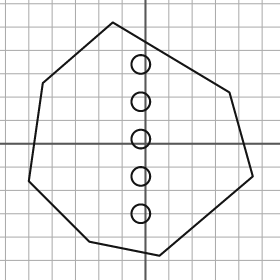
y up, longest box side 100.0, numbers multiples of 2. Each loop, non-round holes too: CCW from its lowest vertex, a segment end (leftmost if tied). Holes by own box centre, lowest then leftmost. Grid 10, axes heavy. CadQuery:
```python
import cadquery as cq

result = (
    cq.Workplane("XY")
    .moveTo(6.0, -48.0)
    .lineTo(46.0, -14.0)
    .lineTo(36.0, 22.0)
    .lineTo(-14.0, 52.0)
    .lineTo(-44.0, 26.0)
    .lineTo(-50.0, -16.0)
    .lineTo(-24.0, -42.0)
    .close()
    .moveTo(-2.0, -30.0)
    .circle(4.0)
    .moveTo(-2.0, -14.0)
    .circle(4.0)
    .moveTo(-2.0, 2.0)
    .circle(4.0)
    .moveTo(-2.0, 18.0)
    .circle(4.0)
    .moveTo(-2.0, 34.0)
    .circle(4.0)
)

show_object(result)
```